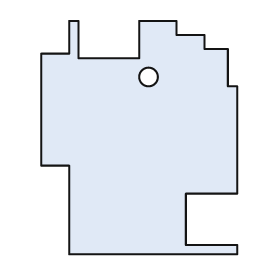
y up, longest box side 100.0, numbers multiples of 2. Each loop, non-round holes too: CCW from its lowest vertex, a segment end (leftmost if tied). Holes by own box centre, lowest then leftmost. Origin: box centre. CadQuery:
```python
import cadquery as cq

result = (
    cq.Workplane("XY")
    .moveTo(-30.0, -50.0)
    .lineTo(42.0, -50.0)
    .lineTo(42.0, -46.0)
    .lineTo(20.0, -46.0)
    .lineTo(20.0, -24.0)
    .lineTo(42.0, -24.0)
    .lineTo(42.0, 22.0)
    .lineTo(38.0, 22.0)
    .lineTo(38.0, 38.0)
    .lineTo(28.0, 38.0)
    .lineTo(28.0, 44.0)
    .lineTo(16.0, 44.0)
    .lineTo(16.0, 50.0)
    .lineTo(0.0, 50.0)
    .lineTo(0.0, 34.0)
    .lineTo(-26.0, 34.0)
    .lineTo(-26.0, 50.0)
    .lineTo(-30.0, 50.0)
    .lineTo(-30.0, 36.0)
    .lineTo(-42.0, 36.0)
    .lineTo(-42.0, -12.0)
    .lineTo(-30.0, -12.0)
    .close()
    .moveTo(4.0, 26.0)
    .circle(4.0)
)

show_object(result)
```